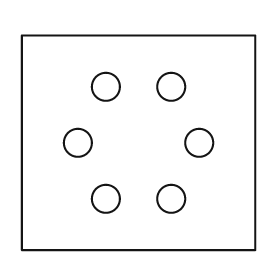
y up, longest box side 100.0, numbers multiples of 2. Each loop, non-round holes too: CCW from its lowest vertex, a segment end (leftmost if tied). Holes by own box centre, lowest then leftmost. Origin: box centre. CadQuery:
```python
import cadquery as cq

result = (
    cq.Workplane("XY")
    .moveTo(-50.0, -46.0)
    .lineTo(50.0, -46.0)
    .lineTo(50.0, 46.0)
    .lineTo(-50.0, 46.0)
    .close()
    .moveTo(-14.0, -24.0)
    .circle(6.0)
    .moveTo(14.0, -24.0)
    .circle(6.0)
    .moveTo(-26.0, 0.0)
    .circle(6.0)
    .moveTo(26.0, 0.0)
    .circle(6.0)
    .moveTo(-14.0, 24.0)
    .circle(6.0)
    .moveTo(14.0, 24.0)
    .circle(6.0)
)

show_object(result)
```